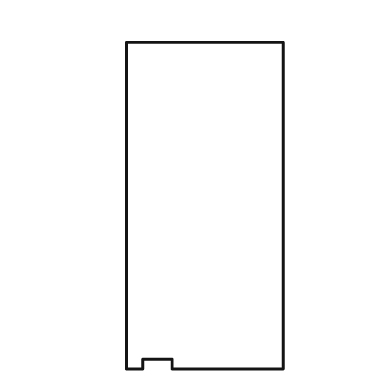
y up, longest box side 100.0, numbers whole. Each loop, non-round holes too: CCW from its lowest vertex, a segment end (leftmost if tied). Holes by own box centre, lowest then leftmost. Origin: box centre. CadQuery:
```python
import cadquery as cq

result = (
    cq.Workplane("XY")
    .moveTo(-24.0, -50.0)
    .lineTo(-19.0, -50.0)
    .lineTo(-19.0, -47.0)
    .lineTo(-10.0, -47.0)
    .lineTo(-10.0, -50.0)
    .lineTo(24.0, -50.0)
    .lineTo(24.0, 50.0)
    .lineTo(-24.0, 50.0)
    .close()
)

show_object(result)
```